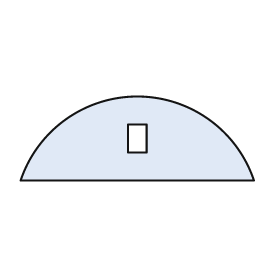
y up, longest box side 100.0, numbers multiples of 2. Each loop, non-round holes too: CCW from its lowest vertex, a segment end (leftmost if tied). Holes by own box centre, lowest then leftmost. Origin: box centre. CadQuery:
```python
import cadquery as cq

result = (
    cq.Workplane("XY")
    .moveTo(-50.0, -18.0)
    .lineTo(50.0, -18.0)
    .threePointArc((0.0, 18.0), (-50.0, -18.0))
    .close()
    .moveTo(-4.0, -6.0)
    .lineTo(4.0, -6.0)
    .lineTo(4.0, 6.0)
    .lineTo(-4.0, 6.0)
    .close()
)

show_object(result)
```